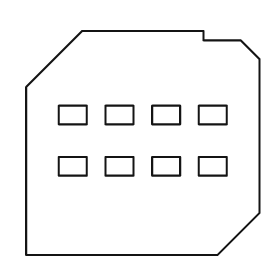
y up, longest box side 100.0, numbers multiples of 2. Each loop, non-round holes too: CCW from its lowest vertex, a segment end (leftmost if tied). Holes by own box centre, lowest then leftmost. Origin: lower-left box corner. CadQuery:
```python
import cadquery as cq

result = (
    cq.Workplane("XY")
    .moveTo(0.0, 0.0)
    .lineTo(82.0, 0.0)
    .lineTo(100.0, 18.0)
    .lineTo(100.0, 84.0)
    .lineTo(92.0, 92.0)
    .lineTo(76.0, 92.0)
    .lineTo(76.0, 96.0)
    .lineTo(24.0, 96.0)
    .lineTo(0.0, 72.0)
    .close()
    .moveTo(14.0, 34.0)
    .lineTo(26.0, 34.0)
    .lineTo(26.0, 42.0)
    .lineTo(14.0, 42.0)
    .close()
    .moveTo(34.0, 34.0)
    .lineTo(46.0, 34.0)
    .lineTo(46.0, 42.0)
    .lineTo(34.0, 42.0)
    .close()
    .moveTo(54.0, 34.0)
    .lineTo(66.0, 34.0)
    .lineTo(66.0, 42.0)
    .lineTo(54.0, 42.0)
    .close()
    .moveTo(74.0, 34.0)
    .lineTo(86.0, 34.0)
    .lineTo(86.0, 42.0)
    .lineTo(74.0, 42.0)
    .close()
    .moveTo(14.0, 56.0)
    .lineTo(26.0, 56.0)
    .lineTo(26.0, 64.0)
    .lineTo(14.0, 64.0)
    .close()
    .moveTo(34.0, 56.0)
    .lineTo(46.0, 56.0)
    .lineTo(46.0, 64.0)
    .lineTo(34.0, 64.0)
    .close()
    .moveTo(54.0, 56.0)
    .lineTo(66.0, 56.0)
    .lineTo(66.0, 64.0)
    .lineTo(54.0, 64.0)
    .close()
    .moveTo(74.0, 56.0)
    .lineTo(86.0, 56.0)
    .lineTo(86.0, 64.0)
    .lineTo(74.0, 64.0)
    .close()
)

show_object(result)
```